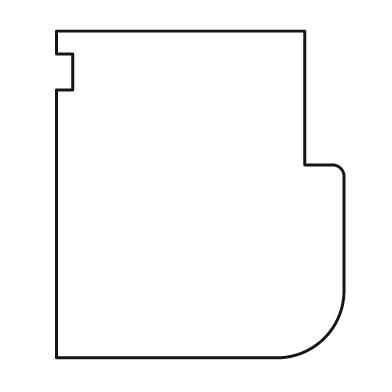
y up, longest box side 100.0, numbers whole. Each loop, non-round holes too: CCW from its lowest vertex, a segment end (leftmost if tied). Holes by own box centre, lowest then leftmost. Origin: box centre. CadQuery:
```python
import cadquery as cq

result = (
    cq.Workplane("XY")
    .moveTo(-44.0, -50.0)
    .lineTo(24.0, -50.0)
    .threePointArc((38.0, -44.0), (44.0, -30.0))
    .lineTo(44.0, 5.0)
    .threePointArc((43.0, 8.0), (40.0, 9.0))
    .lineTo(32.0, 9.0)
    .lineTo(32.0, 50.0)
    .lineTo(-44.0, 50.0)
    .lineTo(-44.0, 43.0)
    .lineTo(-39.0, 43.0)
    .lineTo(-39.0, 32.0)
    .lineTo(-44.0, 32.0)
    .close()
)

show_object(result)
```